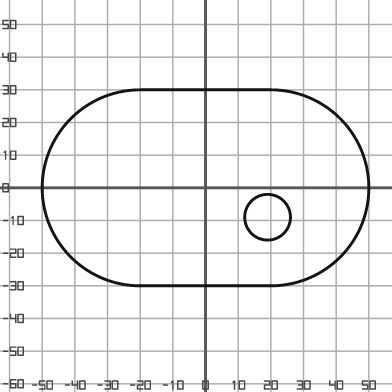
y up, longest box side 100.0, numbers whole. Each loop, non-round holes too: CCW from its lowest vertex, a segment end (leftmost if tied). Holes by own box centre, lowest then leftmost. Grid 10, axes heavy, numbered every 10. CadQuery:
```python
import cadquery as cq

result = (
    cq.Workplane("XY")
    .moveTo(-20.0, -30.0)
    .lineTo(20.0, -30.0)
    .threePointArc((50.0, 0.0), (20.0, 30.0))
    .lineTo(-20.0, 30.0)
    .threePointArc((-50.0, 0.0), (-20.0, -30.0))
    .close()
    .moveTo(19.0, -9.0)
    .circle(7.0)
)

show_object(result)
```